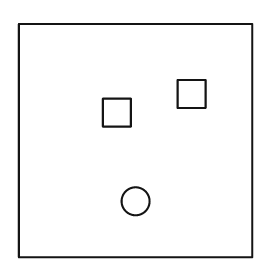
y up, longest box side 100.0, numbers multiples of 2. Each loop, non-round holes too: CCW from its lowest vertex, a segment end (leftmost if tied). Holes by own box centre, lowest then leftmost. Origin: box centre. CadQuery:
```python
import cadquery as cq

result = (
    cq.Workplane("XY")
    .moveTo(-50.0, -50.0)
    .lineTo(50.0, -50.0)
    .lineTo(50.0, 50.0)
    .lineTo(-50.0, 50.0)
    .close()
    .moveTo(0.0, -26.0)
    .circle(6.0)
    .moveTo(-14.0, 6.0)
    .lineTo(-2.0, 6.0)
    .lineTo(-2.0, 18.0)
    .lineTo(-14.0, 18.0)
    .close()
    .moveTo(18.0, 14.0)
    .lineTo(30.0, 14.0)
    .lineTo(30.0, 26.0)
    .lineTo(18.0, 26.0)
    .close()
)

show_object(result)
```